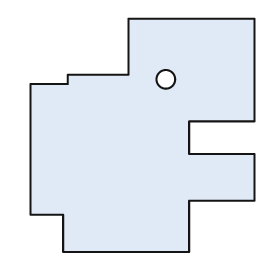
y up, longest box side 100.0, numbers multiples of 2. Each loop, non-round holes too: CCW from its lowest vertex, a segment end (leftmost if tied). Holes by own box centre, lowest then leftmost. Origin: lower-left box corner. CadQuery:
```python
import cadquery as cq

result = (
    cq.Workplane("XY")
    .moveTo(14.0, 0.0)
    .lineTo(68.0, 0.0)
    .lineTo(68.0, 22.0)
    .lineTo(96.0, 22.0)
    .lineTo(96.0, 42.0)
    .lineTo(68.0, 42.0)
    .lineTo(68.0, 56.0)
    .lineTo(96.0, 56.0)
    .lineTo(96.0, 100.0)
    .lineTo(42.0, 100.0)
    .lineTo(42.0, 76.0)
    .lineTo(16.0, 76.0)
    .lineTo(16.0, 72.0)
    .lineTo(0.0, 72.0)
    .lineTo(0.0, 16.0)
    .lineTo(14.0, 16.0)
    .close()
    .moveTo(58.0, 74.0)
    .circle(4.0)
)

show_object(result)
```